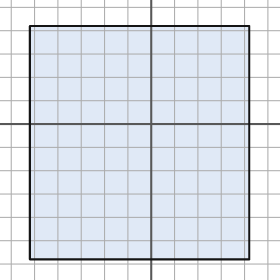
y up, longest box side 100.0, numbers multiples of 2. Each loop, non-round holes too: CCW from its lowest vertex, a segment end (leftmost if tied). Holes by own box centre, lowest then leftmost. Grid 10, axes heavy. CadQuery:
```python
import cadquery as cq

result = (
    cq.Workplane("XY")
    .moveTo(-52.0, -58.0)
    .lineTo(42.0, -58.0)
    .lineTo(42.0, 42.0)
    .lineTo(-52.0, 42.0)
    .close()
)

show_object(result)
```